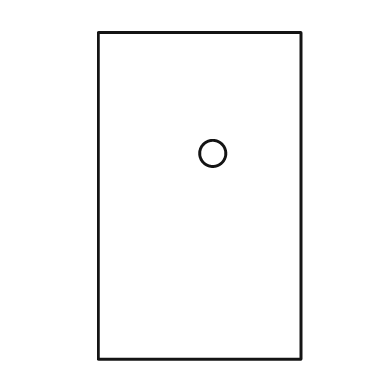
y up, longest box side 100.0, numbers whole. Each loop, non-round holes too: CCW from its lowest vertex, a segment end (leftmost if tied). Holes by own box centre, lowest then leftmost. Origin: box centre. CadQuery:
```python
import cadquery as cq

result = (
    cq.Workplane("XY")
    .moveTo(-31.0, -50.0)
    .lineTo(31.0, -50.0)
    .lineTo(31.0, 50.0)
    .lineTo(-31.0, 50.0)
    .close()
    .moveTo(4.0, 13.0)
    .circle(4.0)
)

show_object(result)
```